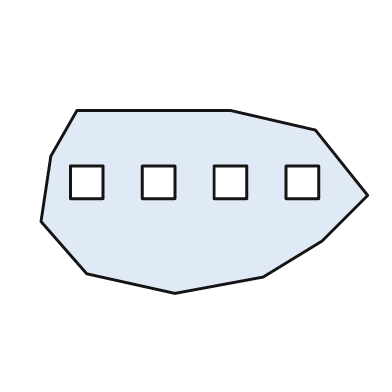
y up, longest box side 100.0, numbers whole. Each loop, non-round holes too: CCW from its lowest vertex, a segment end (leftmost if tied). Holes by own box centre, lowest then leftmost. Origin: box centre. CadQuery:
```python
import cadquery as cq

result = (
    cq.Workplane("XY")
    .moveTo(-9.0, -28.0)
    .lineTo(18.0, -23.0)
    .lineTo(36.0, -12.0)
    .lineTo(50.0, 2.0)
    .lineTo(34.0, 22.0)
    .lineTo(8.0, 28.0)
    .lineTo(-39.0, 28.0)
    .lineTo(-47.0, 14.0)
    .lineTo(-50.0, -6.0)
    .lineTo(-36.0, -22.0)
    .close()
    .moveTo(-41.0, 1.0)
    .lineTo(-31.0, 1.0)
    .lineTo(-31.0, 11.0)
    .lineTo(-41.0, 11.0)
    .close()
    .moveTo(-19.0, 1.0)
    .lineTo(-9.0, 1.0)
    .lineTo(-9.0, 11.0)
    .lineTo(-19.0, 11.0)
    .close()
    .moveTo(3.0, 1.0)
    .lineTo(13.0, 1.0)
    .lineTo(13.0, 11.0)
    .lineTo(3.0, 11.0)
    .close()
    .moveTo(25.0, 1.0)
    .lineTo(35.0, 1.0)
    .lineTo(35.0, 11.0)
    .lineTo(25.0, 11.0)
    .close()
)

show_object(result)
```